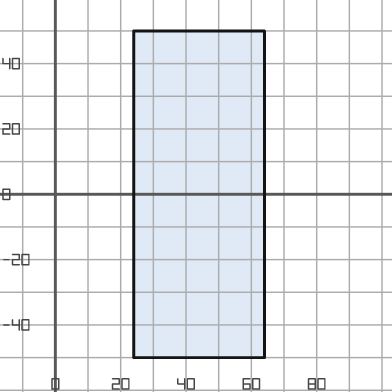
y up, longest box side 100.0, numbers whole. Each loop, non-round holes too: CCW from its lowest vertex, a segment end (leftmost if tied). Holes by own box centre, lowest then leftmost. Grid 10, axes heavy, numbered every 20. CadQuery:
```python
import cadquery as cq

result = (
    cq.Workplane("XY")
    .moveTo(24.0, -50.0)
    .lineTo(64.0, -50.0)
    .lineTo(64.0, 50.0)
    .lineTo(24.0, 50.0)
    .close()
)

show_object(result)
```